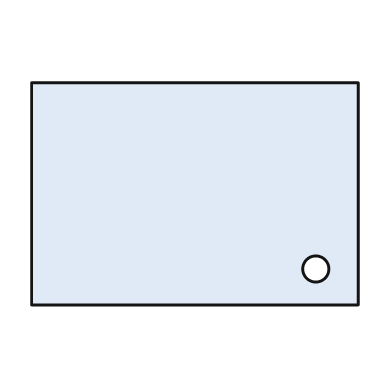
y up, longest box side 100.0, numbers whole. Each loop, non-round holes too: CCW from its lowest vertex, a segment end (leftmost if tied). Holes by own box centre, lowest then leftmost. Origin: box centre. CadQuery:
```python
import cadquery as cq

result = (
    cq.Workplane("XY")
    .moveTo(-50.0, -34.0)
    .lineTo(50.0, -34.0)
    .lineTo(50.0, 34.0)
    .lineTo(-50.0, 34.0)
    .close()
    .moveTo(37.0, -23.0)
    .circle(4.0)
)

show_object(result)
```